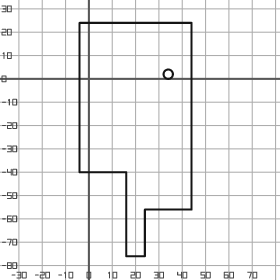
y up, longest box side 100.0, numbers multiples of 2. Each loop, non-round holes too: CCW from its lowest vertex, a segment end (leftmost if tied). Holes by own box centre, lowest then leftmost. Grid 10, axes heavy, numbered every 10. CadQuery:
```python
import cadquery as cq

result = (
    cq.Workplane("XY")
    .moveTo(16.0, -76.0)
    .lineTo(24.0, -76.0)
    .lineTo(24.0, -56.0)
    .lineTo(44.0, -56.0)
    .lineTo(44.0, 24.0)
    .lineTo(-4.0, 24.0)
    .lineTo(-4.0, -40.0)
    .lineTo(16.0, -40.0)
    .close()
    .moveTo(34.0, 2.0)
    .circle(2.0)
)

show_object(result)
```